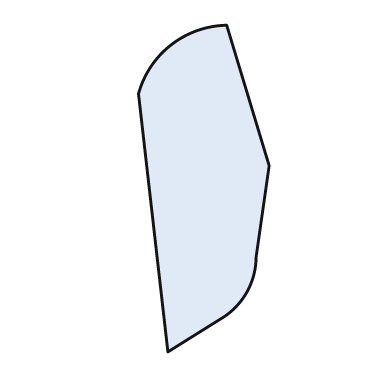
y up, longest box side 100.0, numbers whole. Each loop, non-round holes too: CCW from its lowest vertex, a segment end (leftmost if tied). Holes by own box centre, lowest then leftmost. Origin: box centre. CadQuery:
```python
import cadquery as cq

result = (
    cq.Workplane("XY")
    .moveTo(-11.0, -50.0)
    .lineTo(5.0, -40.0)
    .threePointArc((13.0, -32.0), (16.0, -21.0))
    .lineTo(20.0, 7.0)
    .lineTo(7.0, 50.0)
    .threePointArc((-10.0, 44.0), (-20.0, 29.0))
    .close()
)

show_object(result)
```